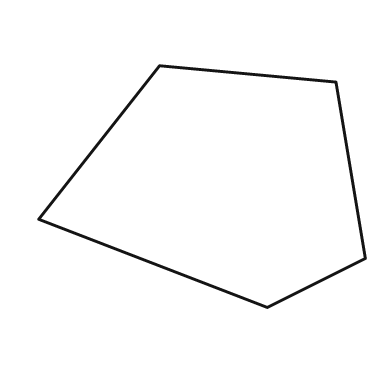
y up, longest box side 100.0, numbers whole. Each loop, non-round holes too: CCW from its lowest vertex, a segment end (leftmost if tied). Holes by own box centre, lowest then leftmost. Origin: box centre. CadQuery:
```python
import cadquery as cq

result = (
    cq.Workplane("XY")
    .moveTo(20.0, -37.0)
    .lineTo(50.0, -22.0)
    .lineTo(41.0, 32.0)
    .lineTo(-13.0, 37.0)
    .lineTo(-50.0, -10.0)
    .close()
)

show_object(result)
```